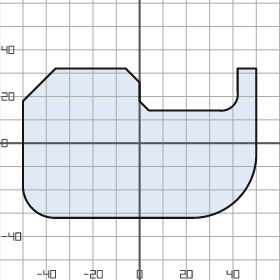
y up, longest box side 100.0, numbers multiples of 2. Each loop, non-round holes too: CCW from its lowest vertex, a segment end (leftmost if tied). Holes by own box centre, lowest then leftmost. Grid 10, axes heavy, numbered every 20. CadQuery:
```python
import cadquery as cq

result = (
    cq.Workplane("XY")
    .moveTo(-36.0, -32.0)
    .lineTo(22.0, -32.0)
    .threePointArc((42.0, -24.0), (50.0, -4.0))
    .lineTo(50.0, 32.0)
    .lineTo(42.0, 32.0)
    .lineTo(42.0, 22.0)
    .threePointArc((40.0, 16.0), (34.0, 14.0))
    .lineTo(4.0, 14.0)
    .lineTo(0.0, 18.0)
    .lineTo(0.0, 26.0)
    .lineTo(-6.0, 32.0)
    .lineTo(-36.0, 32.0)
    .lineTo(-50.0, 18.0)
    .lineTo(-50.0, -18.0)
    .threePointArc((-46.0, -28.0), (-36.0, -32.0))
    .close()
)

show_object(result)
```